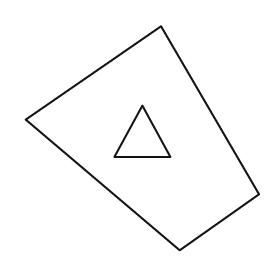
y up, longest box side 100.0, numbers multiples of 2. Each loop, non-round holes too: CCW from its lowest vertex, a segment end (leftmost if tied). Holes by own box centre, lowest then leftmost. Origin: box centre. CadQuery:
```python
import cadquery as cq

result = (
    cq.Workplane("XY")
    .moveTo(16.0, -48.0)
    .lineTo(50.0, -24.0)
    .lineTo(8.0, 48.0)
    .lineTo(-50.0, 8.0)
    .close()
    .moveTo(-12.0, -8.0)
    .lineTo(12.0, -8.0)
    .lineTo(0.0, 14.0)
    .close()
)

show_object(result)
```